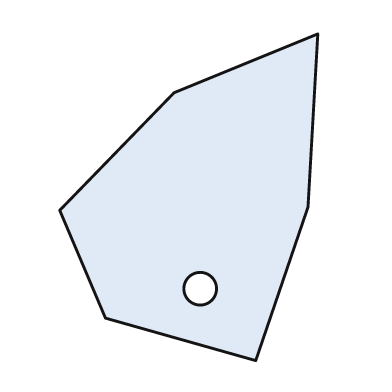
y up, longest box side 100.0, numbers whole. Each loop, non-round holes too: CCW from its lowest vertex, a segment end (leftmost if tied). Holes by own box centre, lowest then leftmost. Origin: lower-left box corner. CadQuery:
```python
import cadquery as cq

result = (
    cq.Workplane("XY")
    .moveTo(60.0, 0.0)
    .lineTo(76.0, 47.0)
    .lineTo(79.0, 100.0)
    .lineTo(35.0, 82.0)
    .lineTo(0.0, 46.0)
    .lineTo(14.0, 13.0)
    .close()
    .moveTo(43.0, 22.0)
    .circle(5.0)
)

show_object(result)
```